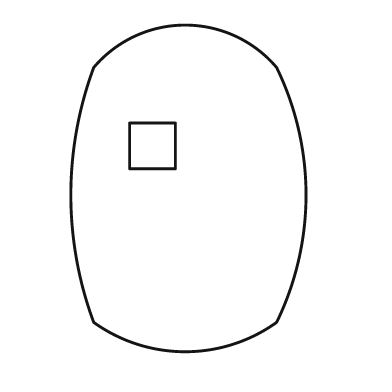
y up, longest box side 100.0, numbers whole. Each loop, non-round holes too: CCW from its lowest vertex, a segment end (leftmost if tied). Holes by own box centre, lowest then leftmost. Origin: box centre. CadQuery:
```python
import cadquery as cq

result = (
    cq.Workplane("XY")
    .moveTo(-29.0, -41.0)
    .threePointArc((-1.0, -50.0), (27.0, -41.0))
    .threePointArc((36.0, -2.0), (27.0, 37.0))
    .threePointArc((-1.0, 50.0), (-29.0, 37.0))
    .threePointArc((-36.0, -2.0), (-29.0, -41.0))
    .close()
    .moveTo(-18.0, 6.0)
    .lineTo(-4.0, 6.0)
    .lineTo(-4.0, 20.0)
    .lineTo(-18.0, 20.0)
    .close()
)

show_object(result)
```